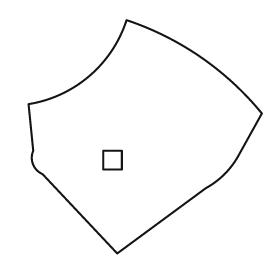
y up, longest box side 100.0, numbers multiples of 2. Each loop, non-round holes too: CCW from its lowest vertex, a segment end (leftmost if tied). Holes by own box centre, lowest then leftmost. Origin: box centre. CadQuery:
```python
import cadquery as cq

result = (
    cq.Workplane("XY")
    .moveTo(-12.0, -50.0)
    .lineTo(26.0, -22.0)
    .threePointArc((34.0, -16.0), (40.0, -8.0))
    .lineTo(50.0, 10.0)
    .threePointArc((24.0, 34.0), (-8.0, 50.0))
    .threePointArc((-24.0, 26.0), (-50.0, 14.0))
    .lineTo(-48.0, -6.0)
    .threePointArc((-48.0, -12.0), (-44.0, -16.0))
    .close()
    .moveTo(-18.0, -14.0)
    .lineTo(-10.0, -14.0)
    .lineTo(-10.0, -6.0)
    .lineTo(-18.0, -6.0)
    .close()
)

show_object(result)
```